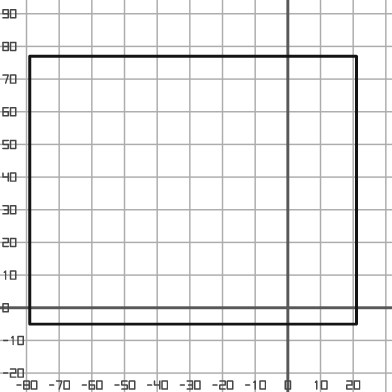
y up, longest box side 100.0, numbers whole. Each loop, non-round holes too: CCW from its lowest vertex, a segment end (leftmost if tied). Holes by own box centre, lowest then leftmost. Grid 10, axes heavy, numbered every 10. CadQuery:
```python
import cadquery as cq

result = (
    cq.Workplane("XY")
    .moveTo(-79.0, -5.0)
    .lineTo(21.0, -5.0)
    .lineTo(21.0, 77.0)
    .lineTo(-79.0, 77.0)
    .close()
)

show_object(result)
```